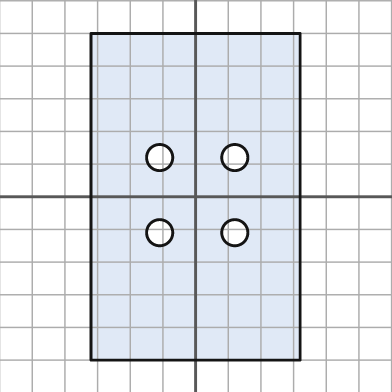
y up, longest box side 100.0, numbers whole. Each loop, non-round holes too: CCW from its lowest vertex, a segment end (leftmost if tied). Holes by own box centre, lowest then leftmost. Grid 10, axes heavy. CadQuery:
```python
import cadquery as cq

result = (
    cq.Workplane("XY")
    .moveTo(-32.0, -50.0)
    .lineTo(32.0, -50.0)
    .lineTo(32.0, 50.0)
    .lineTo(-32.0, 50.0)
    .close()
    .moveTo(-11.0, -11.0)
    .circle(4.0)
    .moveTo(12.0, -11.0)
    .circle(4.0)
    .moveTo(-11.0, 12.0)
    .circle(4.0)
    .moveTo(12.0, 12.0)
    .circle(4.0)
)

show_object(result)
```